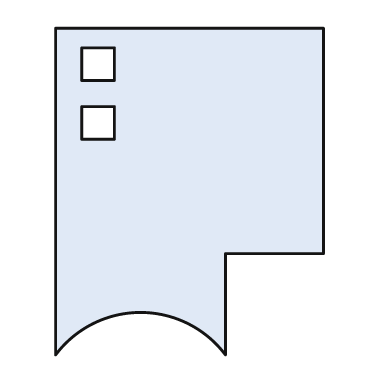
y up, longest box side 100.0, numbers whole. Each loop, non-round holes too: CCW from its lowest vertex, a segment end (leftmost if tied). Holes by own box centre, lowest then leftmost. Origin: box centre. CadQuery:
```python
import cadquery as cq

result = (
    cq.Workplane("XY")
    .moveTo(-41.0, -50.0)
    .threePointArc((-15.0, -37.0), (11.0, -50.0))
    .lineTo(11.0, -19.0)
    .lineTo(41.0, -19.0)
    .lineTo(41.0, 50.0)
    .lineTo(-41.0, 50.0)
    .close()
    .moveTo(-33.0, 16.0)
    .lineTo(-23.0, 16.0)
    .lineTo(-23.0, 26.0)
    .lineTo(-33.0, 26.0)
    .close()
    .moveTo(-33.0, 34.0)
    .lineTo(-23.0, 34.0)
    .lineTo(-23.0, 44.0)
    .lineTo(-33.0, 44.0)
    .close()
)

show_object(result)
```